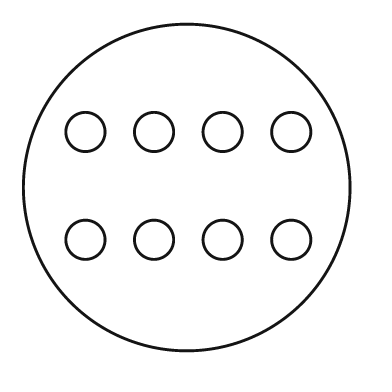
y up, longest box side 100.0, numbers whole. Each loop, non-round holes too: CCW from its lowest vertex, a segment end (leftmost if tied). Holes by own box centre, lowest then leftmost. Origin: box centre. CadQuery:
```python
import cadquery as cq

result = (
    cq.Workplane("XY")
    .moveTo(0.0, 0.0)
    .circle(50.0)
    .moveTo(-31.0, -16.0)
    .circle(6.0)
    .moveTo(-10.0, -16.0)
    .circle(6.0)
    .moveTo(11.0, -16.0)
    .circle(6.0)
    .moveTo(32.0, -16.0)
    .circle(6.0)
    .moveTo(-31.0, 17.0)
    .circle(6.0)
    .moveTo(-10.0, 17.0)
    .circle(6.0)
    .moveTo(11.0, 17.0)
    .circle(6.0)
    .moveTo(32.0, 17.0)
    .circle(6.0)
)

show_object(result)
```